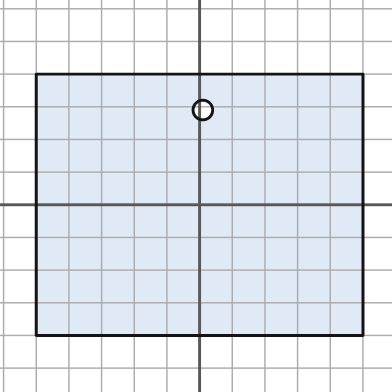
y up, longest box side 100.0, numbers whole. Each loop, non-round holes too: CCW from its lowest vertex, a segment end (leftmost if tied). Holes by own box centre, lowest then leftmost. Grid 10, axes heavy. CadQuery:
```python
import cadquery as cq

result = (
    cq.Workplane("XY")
    .moveTo(-50.0, -40.0)
    .lineTo(50.0, -40.0)
    .lineTo(50.0, 40.0)
    .lineTo(-50.0, 40.0)
    .close()
    .moveTo(1.0, 29.0)
    .circle(3.0)
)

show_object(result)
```